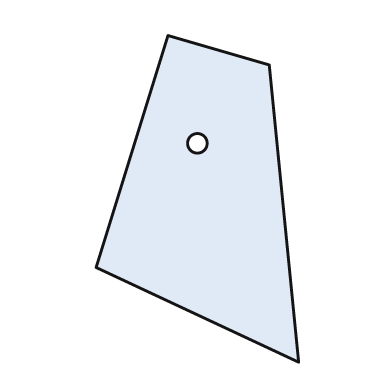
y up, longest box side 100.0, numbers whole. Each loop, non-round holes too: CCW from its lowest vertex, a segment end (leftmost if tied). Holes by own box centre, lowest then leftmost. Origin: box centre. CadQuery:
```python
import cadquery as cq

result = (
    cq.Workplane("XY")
    .moveTo(31.0, -50.0)
    .lineTo(22.0, 41.0)
    .lineTo(-9.0, 50.0)
    .lineTo(-31.0, -21.0)
    .close()
    .moveTo(0.0, 17.0)
    .circle(3.0)
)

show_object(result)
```